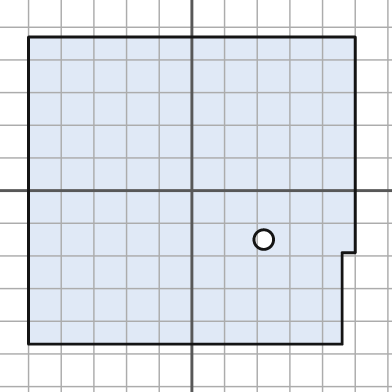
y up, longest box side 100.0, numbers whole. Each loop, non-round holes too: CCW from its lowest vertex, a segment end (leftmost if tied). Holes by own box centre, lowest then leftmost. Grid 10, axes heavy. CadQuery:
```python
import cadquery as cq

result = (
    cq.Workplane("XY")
    .moveTo(-50.0, -47.0)
    .lineTo(46.0, -47.0)
    .lineTo(46.0, -19.0)
    .lineTo(50.0, -19.0)
    .lineTo(50.0, 47.0)
    .lineTo(-50.0, 47.0)
    .close()
    .moveTo(22.0, -15.0)
    .circle(3.0)
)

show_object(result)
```